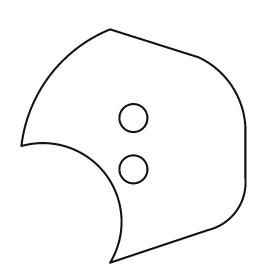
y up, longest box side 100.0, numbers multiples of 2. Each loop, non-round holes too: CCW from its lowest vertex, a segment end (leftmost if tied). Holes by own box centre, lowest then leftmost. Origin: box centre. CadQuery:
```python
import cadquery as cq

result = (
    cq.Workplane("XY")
    .moveTo(-10.0, -50.0)
    .lineTo(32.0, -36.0)
    .threePointArc((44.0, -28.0), (48.0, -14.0))
    .lineTo(48.0, 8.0)
    .threePointArc((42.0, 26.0), (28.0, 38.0))
    .lineTo(-10.0, 50.0)
    .threePointArc((-36.0, 30.0), (-48.0, 0.0))
    .threePointArc((-12.0, -12.0), (-10.0, -50.0))
    .close()
    .moveTo(0.0, -10.0)
    .circle(6.0)
    .moveTo(0.0, 12.0)
    .circle(6.0)
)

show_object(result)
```